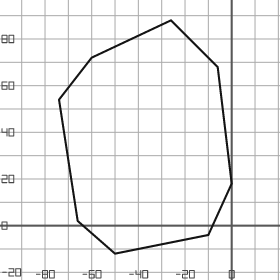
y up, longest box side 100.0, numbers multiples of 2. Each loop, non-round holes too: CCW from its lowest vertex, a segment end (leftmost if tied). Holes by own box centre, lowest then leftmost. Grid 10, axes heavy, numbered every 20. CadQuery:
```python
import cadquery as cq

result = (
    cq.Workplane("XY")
    .moveTo(-50.0, -12.0)
    .lineTo(-10.0, -4.0)
    .lineTo(0.0, 18.0)
    .lineTo(-6.0, 68.0)
    .lineTo(-26.0, 88.0)
    .lineTo(-60.0, 72.0)
    .lineTo(-74.0, 54.0)
    .lineTo(-66.0, 2.0)
    .close()
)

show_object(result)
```